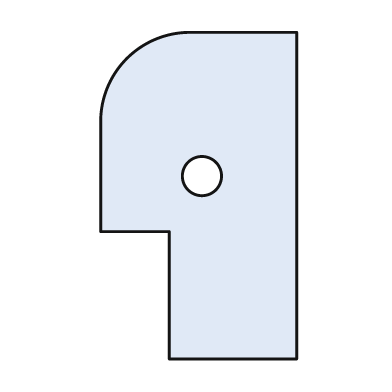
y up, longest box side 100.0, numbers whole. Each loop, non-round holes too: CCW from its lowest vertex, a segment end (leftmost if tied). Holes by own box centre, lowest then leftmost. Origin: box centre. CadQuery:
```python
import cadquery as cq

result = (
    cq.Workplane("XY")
    .moveTo(-9.0, -50.0)
    .lineTo(30.0, -50.0)
    .lineTo(30.0, 50.0)
    .lineTo(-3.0, 50.0)
    .threePointArc((-22.0, 42.0), (-30.0, 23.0))
    .lineTo(-30.0, -11.0)
    .lineTo(-9.0, -11.0)
    .close()
    .moveTo(1.0, 6.0)
    .circle(6.0)
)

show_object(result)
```